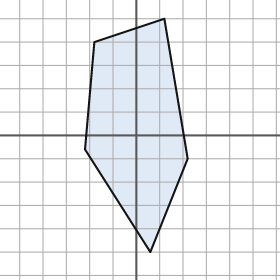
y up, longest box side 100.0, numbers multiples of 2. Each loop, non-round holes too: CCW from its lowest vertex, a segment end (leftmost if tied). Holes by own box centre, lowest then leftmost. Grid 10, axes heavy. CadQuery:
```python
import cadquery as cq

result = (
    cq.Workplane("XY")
    .moveTo(6.0, -50.0)
    .lineTo(22.0, -10.0)
    .lineTo(12.0, 50.0)
    .lineTo(-18.0, 40.0)
    .lineTo(-22.0, -6.0)
    .close()
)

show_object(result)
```